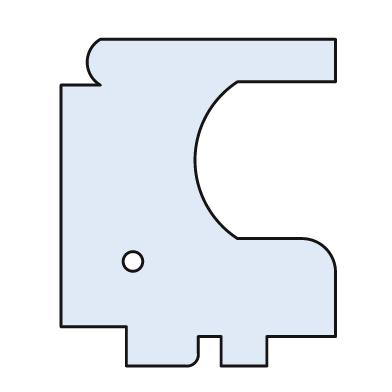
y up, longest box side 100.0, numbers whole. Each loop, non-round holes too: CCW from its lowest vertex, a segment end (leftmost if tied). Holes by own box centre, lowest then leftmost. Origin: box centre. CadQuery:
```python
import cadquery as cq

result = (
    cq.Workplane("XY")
    .moveTo(-22.0, -50.0)
    .lineTo(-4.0, -50.0)
    .threePointArc((-1.0, -49.0), (0.0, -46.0))
    .lineTo(0.0, -41.0)
    .lineTo(7.0, -41.0)
    .lineTo(7.0, -50.0)
    .lineTo(21.0, -50.0)
    .lineTo(21.0, -41.0)
    .lineTo(42.0, -41.0)
    .lineTo(42.0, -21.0)
    .threePointArc((39.0, -14.0), (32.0, -11.0))
    .lineTo(12.0, -11.0)
    .threePointArc((-1.0, 13.0), (12.0, 37.0))
    .lineTo(42.0, 37.0)
    .lineTo(42.0, 50.0)
    .lineTo(-30.0, 50.0)
    .threePointArc((-34.0, 43.0), (-30.0, 36.0))
    .lineTo(-42.0, 36.0)
    .lineTo(-42.0, -38.0)
    .lineTo(-22.0, -38.0)
    .close()
    .moveTo(-20.0, -18.0)
    .circle(3.0)
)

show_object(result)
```